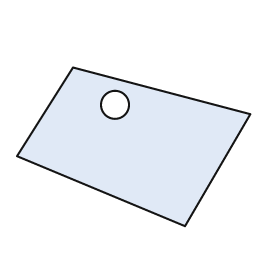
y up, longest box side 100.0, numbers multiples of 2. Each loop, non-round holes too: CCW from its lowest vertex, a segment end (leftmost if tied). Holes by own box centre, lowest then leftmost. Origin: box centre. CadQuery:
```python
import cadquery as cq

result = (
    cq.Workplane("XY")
    .moveTo(22.0, -34.0)
    .lineTo(50.0, 14.0)
    .lineTo(-26.0, 34.0)
    .lineTo(-50.0, -4.0)
    .close()
    .moveTo(-8.0, 18.0)
    .circle(6.0)
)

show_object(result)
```